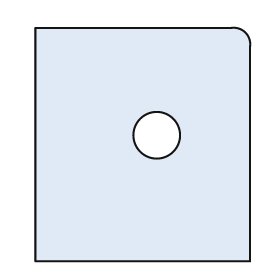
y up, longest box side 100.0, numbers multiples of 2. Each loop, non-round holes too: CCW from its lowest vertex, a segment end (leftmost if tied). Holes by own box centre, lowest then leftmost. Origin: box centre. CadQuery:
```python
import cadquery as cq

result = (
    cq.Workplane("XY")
    .moveTo(-46.0, -50.0)
    .lineTo(46.0, -50.0)
    .lineTo(46.0, 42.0)
    .threePointArc((44.0, 48.0), (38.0, 50.0))
    .lineTo(-46.0, 50.0)
    .close()
    .moveTo(6.0, 4.0)
    .circle(10.0)
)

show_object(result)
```